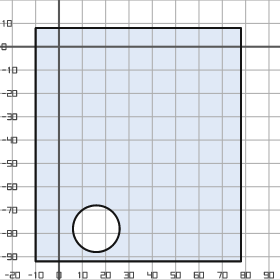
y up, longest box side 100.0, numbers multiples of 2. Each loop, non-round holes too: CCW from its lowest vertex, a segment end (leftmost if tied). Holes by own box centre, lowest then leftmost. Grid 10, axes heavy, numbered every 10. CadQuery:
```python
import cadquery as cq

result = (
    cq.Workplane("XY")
    .moveTo(-10.0, -92.0)
    .lineTo(78.0, -92.0)
    .lineTo(78.0, 8.0)
    .lineTo(-10.0, 8.0)
    .close()
    .moveTo(16.0, -78.0)
    .circle(10.0)
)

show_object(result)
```